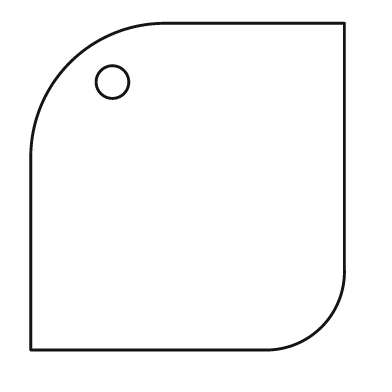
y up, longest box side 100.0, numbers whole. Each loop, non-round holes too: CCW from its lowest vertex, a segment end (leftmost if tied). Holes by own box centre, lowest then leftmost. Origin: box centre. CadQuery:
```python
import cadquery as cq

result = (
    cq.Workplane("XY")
    .moveTo(-48.0, -50.0)
    .lineTo(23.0, -50.0)
    .threePointArc((41.0, -43.0), (48.0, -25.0))
    .lineTo(48.0, 50.0)
    .lineTo(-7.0, 50.0)
    .threePointArc((-36.0, 38.0), (-48.0, 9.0))
    .close()
    .moveTo(-23.0, 32.0)
    .circle(5.0)
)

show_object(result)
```